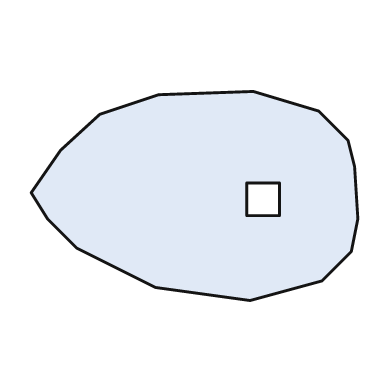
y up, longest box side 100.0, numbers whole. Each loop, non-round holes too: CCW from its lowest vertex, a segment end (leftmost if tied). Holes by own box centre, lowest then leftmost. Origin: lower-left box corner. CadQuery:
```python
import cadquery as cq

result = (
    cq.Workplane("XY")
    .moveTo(67.0, 0.0)
    .lineTo(89.0, 6.0)
    .lineTo(98.0, 15.0)
    .lineTo(100.0, 25.0)
    .lineTo(99.0, 41.0)
    .lineTo(97.0, 49.0)
    .lineTo(88.0, 58.0)
    .lineTo(68.0, 64.0)
    .lineTo(39.0, 63.0)
    .lineTo(21.0, 57.0)
    .lineTo(9.0, 46.0)
    .lineTo(0.0, 33.0)
    .lineTo(5.0, 25.0)
    .lineTo(14.0, 16.0)
    .lineTo(38.0, 4.0)
    .close()
    .moveTo(66.0, 26.0)
    .lineTo(76.0, 26.0)
    .lineTo(76.0, 36.0)
    .lineTo(66.0, 36.0)
    .close()
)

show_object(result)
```